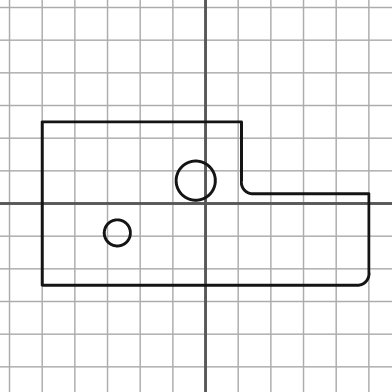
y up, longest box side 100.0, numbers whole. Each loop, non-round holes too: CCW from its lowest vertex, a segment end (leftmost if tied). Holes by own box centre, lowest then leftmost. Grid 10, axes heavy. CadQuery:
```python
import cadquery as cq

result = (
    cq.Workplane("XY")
    .moveTo(-50.0, -25.0)
    .lineTo(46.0, -25.0)
    .threePointArc((49.0, -24.0), (50.0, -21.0))
    .lineTo(50.0, 3.0)
    .lineTo(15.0, 3.0)
    .threePointArc((12.0, 4.0), (11.0, 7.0))
    .lineTo(11.0, 25.0)
    .lineTo(-50.0, 25.0)
    .close()
    .moveTo(-27.0, -9.0)
    .circle(4.0)
    .moveTo(-3.0, 7.0)
    .circle(6.0)
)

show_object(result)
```